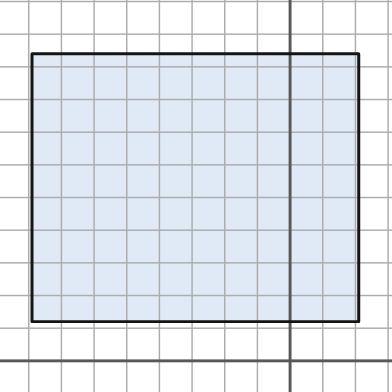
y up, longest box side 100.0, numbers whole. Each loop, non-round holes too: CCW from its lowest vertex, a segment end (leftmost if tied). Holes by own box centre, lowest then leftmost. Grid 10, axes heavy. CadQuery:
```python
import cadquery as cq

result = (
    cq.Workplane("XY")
    .moveTo(-79.0, 12.0)
    .lineTo(21.0, 12.0)
    .lineTo(21.0, 94.0)
    .lineTo(-79.0, 94.0)
    .close()
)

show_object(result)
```